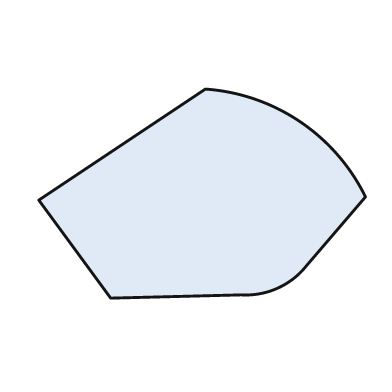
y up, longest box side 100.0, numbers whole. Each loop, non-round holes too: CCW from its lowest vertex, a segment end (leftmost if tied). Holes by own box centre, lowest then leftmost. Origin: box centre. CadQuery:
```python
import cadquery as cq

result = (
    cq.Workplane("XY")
    .moveTo(-28.0, -32.0)
    .lineTo(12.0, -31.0)
    .threePointArc((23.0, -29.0), (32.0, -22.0))
    .lineTo(50.0, -1.0)
    .threePointArc((30.0, 22.0), (1.0, 32.0))
    .lineTo(-50.0, -2.0)
    .close()
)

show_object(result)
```